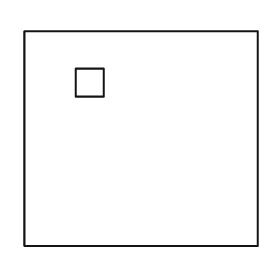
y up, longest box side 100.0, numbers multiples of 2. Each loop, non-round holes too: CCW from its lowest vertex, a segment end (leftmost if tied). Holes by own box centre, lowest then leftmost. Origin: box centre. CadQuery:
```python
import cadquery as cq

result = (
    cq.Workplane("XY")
    .moveTo(-50.0, -46.0)
    .lineTo(50.0, -46.0)
    .lineTo(50.0, 46.0)
    .lineTo(-50.0, 46.0)
    .close()
    .moveTo(-28.0, 18.0)
    .lineTo(-16.0, 18.0)
    .lineTo(-16.0, 30.0)
    .lineTo(-28.0, 30.0)
    .close()
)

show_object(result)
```